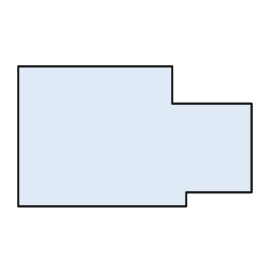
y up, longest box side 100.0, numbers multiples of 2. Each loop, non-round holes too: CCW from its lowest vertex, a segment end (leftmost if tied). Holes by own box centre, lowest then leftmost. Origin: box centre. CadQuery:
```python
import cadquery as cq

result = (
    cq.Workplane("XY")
    .moveTo(-50.0, -30.0)
    .lineTo(22.0, -30.0)
    .lineTo(22.0, -24.0)
    .lineTo(50.0, -24.0)
    .lineTo(50.0, 14.0)
    .lineTo(16.0, 14.0)
    .lineTo(16.0, 30.0)
    .lineTo(-50.0, 30.0)
    .close()
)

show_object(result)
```